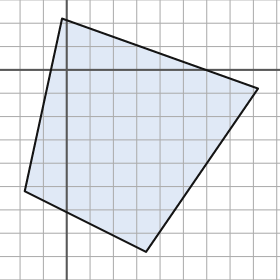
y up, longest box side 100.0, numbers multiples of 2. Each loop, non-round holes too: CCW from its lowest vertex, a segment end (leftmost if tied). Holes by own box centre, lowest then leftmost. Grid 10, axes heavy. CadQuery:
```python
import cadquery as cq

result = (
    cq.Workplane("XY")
    .moveTo(34.0, -78.0)
    .lineTo(82.0, -8.0)
    .lineTo(-2.0, 22.0)
    .lineTo(-18.0, -52.0)
    .close()
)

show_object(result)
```